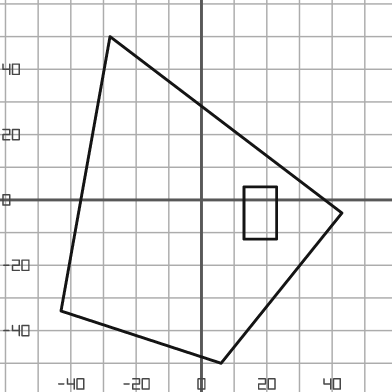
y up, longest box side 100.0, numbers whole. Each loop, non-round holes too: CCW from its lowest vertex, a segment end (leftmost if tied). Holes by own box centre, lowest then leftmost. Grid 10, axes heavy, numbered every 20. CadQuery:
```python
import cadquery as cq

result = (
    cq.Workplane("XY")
    .moveTo(6.0, -50.0)
    .lineTo(43.0, -4.0)
    .lineTo(-28.0, 50.0)
    .lineTo(-43.0, -34.0)
    .close()
    .moveTo(13.0, -12.0)
    .lineTo(23.0, -12.0)
    .lineTo(23.0, 4.0)
    .lineTo(13.0, 4.0)
    .close()
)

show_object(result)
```